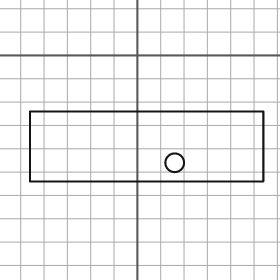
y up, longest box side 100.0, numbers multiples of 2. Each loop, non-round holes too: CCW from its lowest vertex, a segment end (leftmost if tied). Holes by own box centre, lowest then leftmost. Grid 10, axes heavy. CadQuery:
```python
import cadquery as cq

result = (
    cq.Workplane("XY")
    .moveTo(-46.0, -54.0)
    .lineTo(54.0, -54.0)
    .lineTo(54.0, -24.0)
    .lineTo(-46.0, -24.0)
    .close()
    .moveTo(16.0, -46.0)
    .circle(4.0)
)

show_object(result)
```